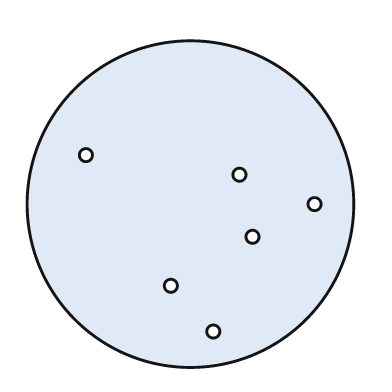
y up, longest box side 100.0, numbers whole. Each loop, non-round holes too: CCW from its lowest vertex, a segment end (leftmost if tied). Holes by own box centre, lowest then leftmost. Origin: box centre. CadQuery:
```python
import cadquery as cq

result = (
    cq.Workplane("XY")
    .moveTo(0.0, 0.0)
    .circle(50.0)
    .moveTo(7.0, -39.0)
    .circle(2.0)
    .moveTo(-6.0, -25.0)
    .circle(2.0)
    .moveTo(19.0, -10.0)
    .circle(2.0)
    .moveTo(38.0, 0.0)
    .circle(2.0)
    .moveTo(15.0, 9.0)
    .circle(2.0)
    .moveTo(-32.0, 15.0)
    .circle(2.0)
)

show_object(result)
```